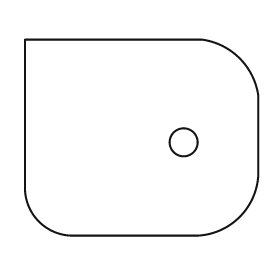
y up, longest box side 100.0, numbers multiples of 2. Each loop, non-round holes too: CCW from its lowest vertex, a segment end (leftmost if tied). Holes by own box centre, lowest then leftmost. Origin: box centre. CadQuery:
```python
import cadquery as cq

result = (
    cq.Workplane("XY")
    .moveTo(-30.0, -42.0)
    .lineTo(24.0, -42.0)
    .threePointArc((42.0, -34.0), (50.0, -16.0))
    .lineTo(50.0, 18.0)
    .threePointArc((42.0, 34.0), (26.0, 42.0))
    .lineTo(-50.0, 42.0)
    .lineTo(-50.0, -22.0)
    .threePointArc((-44.0, -36.0), (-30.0, -42.0))
    .close()
    .moveTo(18.0, -2.0)
    .circle(6.0)
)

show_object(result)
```